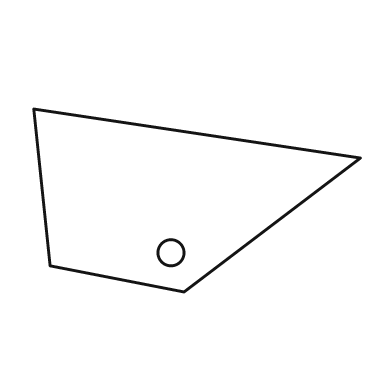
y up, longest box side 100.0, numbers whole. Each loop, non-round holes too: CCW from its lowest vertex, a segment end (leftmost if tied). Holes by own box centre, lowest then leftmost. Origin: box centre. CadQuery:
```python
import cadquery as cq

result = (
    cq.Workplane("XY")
    .moveTo(-4.0, -28.0)
    .lineTo(50.0, 13.0)
    .lineTo(-50.0, 28.0)
    .lineTo(-45.0, -20.0)
    .close()
    .moveTo(-8.0, -16.0)
    .circle(4.0)
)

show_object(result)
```